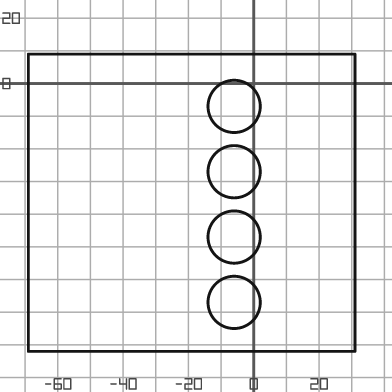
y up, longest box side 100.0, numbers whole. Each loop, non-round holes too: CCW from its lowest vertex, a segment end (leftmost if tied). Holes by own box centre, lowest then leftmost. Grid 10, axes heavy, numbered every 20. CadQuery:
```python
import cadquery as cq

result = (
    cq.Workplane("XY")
    .moveTo(-69.0, -82.0)
    .lineTo(31.0, -82.0)
    .lineTo(31.0, 9.0)
    .lineTo(-69.0, 9.0)
    .close()
    .moveTo(-6.0, -67.0)
    .circle(8.0)
    .moveTo(-6.0, -47.0)
    .circle(8.0)
    .moveTo(-6.0, -27.0)
    .circle(8.0)
    .moveTo(-6.0, -7.0)
    .circle(8.0)
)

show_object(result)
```